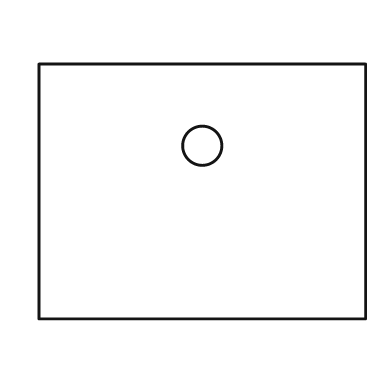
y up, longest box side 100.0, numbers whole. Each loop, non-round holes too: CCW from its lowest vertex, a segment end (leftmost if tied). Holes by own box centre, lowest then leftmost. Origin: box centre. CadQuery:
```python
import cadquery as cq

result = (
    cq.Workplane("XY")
    .moveTo(-50.0, -39.0)
    .lineTo(50.0, -39.0)
    .lineTo(50.0, 39.0)
    .lineTo(-50.0, 39.0)
    .close()
    .moveTo(0.0, 14.0)
    .circle(6.0)
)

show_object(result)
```